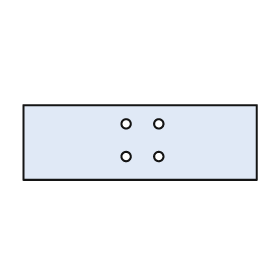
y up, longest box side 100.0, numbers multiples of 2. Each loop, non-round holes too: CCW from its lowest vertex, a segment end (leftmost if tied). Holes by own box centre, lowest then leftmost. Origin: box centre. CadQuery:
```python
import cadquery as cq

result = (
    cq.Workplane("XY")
    .moveTo(-50.0, -16.0)
    .lineTo(50.0, -16.0)
    .lineTo(50.0, 16.0)
    .lineTo(-50.0, 16.0)
    .close()
    .moveTo(-6.0, -6.0)
    .circle(2.0)
    .moveTo(8.0, -6.0)
    .circle(2.0)
    .moveTo(-6.0, 8.0)
    .circle(2.0)
    .moveTo(8.0, 8.0)
    .circle(2.0)
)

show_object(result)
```